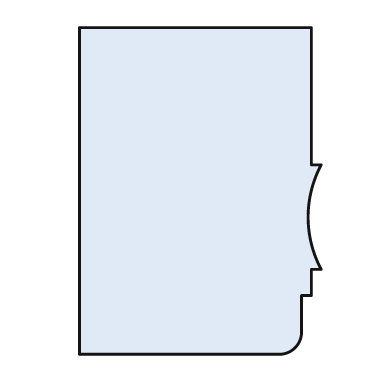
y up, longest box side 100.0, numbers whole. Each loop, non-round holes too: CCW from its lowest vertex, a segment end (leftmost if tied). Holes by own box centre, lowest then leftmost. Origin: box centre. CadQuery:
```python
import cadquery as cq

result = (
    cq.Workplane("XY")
    .moveTo(-37.0, -50.0)
    .lineTo(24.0, -50.0)
    .threePointArc((29.0, -48.0), (31.0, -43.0))
    .lineTo(31.0, -32.0)
    .lineTo(34.0, -32.0)
    .lineTo(34.0, -24.0)
    .lineTo(37.0, -24.0)
    .threePointArc((33.0, -8.0), (37.0, 8.0))
    .lineTo(34.0, 8.0)
    .lineTo(34.0, 50.0)
    .lineTo(-37.0, 50.0)
    .close()
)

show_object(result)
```